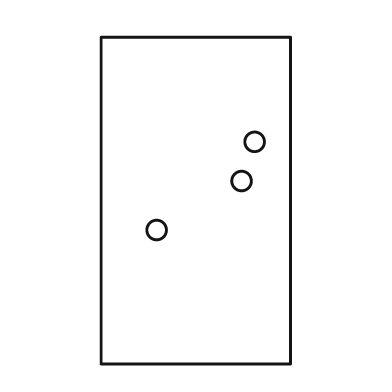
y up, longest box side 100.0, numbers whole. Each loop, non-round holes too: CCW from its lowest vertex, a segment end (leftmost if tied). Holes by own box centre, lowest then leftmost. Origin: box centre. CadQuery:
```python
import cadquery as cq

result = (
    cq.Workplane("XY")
    .moveTo(-29.0, -50.0)
    .lineTo(29.0, -50.0)
    .lineTo(29.0, 50.0)
    .lineTo(-29.0, 50.0)
    .close()
    .moveTo(-12.0, -9.0)
    .circle(3.0)
    .moveTo(14.0, 6.0)
    .circle(3.0)
    .moveTo(18.0, 18.0)
    .circle(3.0)
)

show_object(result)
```